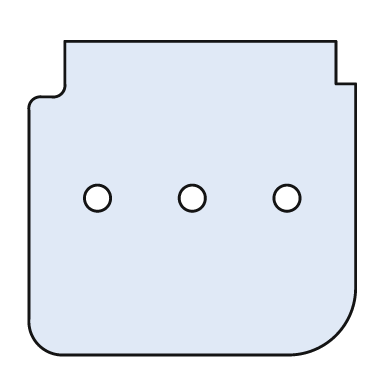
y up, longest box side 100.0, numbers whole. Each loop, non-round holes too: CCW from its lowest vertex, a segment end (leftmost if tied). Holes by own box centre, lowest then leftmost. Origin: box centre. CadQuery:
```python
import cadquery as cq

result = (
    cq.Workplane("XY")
    .moveTo(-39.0, -48.0)
    .lineTo(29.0, -48.0)
    .threePointArc((44.0, -42.0), (50.0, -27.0))
    .lineTo(50.0, 35.0)
    .lineTo(44.0, 35.0)
    .lineTo(44.0, 48.0)
    .lineTo(-39.0, 48.0)
    .lineTo(-39.0, 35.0)
    .threePointArc((-40.0, 32.0), (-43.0, 31.0))
    .lineTo(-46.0, 31.0)
    .threePointArc((-49.0, 30.0), (-50.0, 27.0))
    .lineTo(-50.0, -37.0)
    .threePointArc((-47.0, -45.0), (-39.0, -48.0))
    .close()
    .moveTo(-29.0, 0.0)
    .circle(4.0)
    .moveTo(0.0, 0.0)
    .circle(4.0)
    .moveTo(29.0, 0.0)
    .circle(4.0)
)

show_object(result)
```